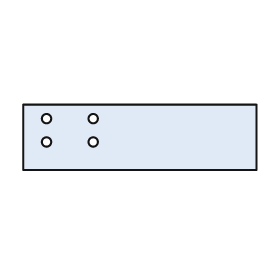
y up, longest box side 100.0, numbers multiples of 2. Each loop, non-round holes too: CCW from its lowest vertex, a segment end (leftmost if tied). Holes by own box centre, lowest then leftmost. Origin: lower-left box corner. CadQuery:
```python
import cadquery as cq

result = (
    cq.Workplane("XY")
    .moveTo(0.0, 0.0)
    .lineTo(100.0, 0.0)
    .lineTo(100.0, 28.0)
    .lineTo(0.0, 28.0)
    .close()
    .moveTo(10.0, 12.0)
    .circle(2.0)
    .moveTo(30.0, 12.0)
    .circle(2.0)
    .moveTo(10.0, 22.0)
    .circle(2.0)
    .moveTo(30.0, 22.0)
    .circle(2.0)
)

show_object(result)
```